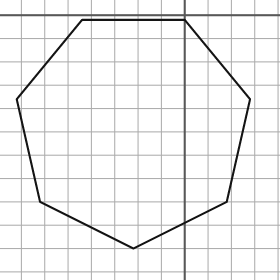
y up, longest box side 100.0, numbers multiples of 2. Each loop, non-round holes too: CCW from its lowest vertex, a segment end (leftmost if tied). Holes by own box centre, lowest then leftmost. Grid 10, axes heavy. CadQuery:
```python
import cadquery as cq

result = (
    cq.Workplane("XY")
    .moveTo(-22.0, -100.0)
    .lineTo(18.0, -80.0)
    .lineTo(28.0, -36.0)
    .lineTo(0.0, -2.0)
    .lineTo(-44.0, -2.0)
    .lineTo(-72.0, -36.0)
    .lineTo(-62.0, -80.0)
    .close()
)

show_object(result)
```